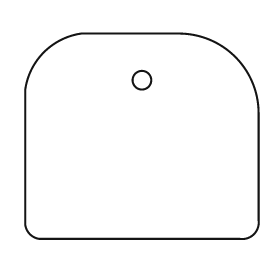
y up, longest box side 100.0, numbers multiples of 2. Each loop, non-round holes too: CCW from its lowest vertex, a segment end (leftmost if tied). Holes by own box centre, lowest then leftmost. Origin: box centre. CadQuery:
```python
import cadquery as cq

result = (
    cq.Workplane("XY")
    .moveTo(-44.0, -44.0)
    .lineTo(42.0, -44.0)
    .threePointArc((48.0, -42.0), (50.0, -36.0))
    .lineTo(50.0, 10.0)
    .threePointArc((40.0, 34.0), (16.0, 44.0))
    .lineTo(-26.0, 44.0)
    .threePointArc((-42.0, 36.0), (-50.0, 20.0))
    .lineTo(-50.0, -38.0)
    .threePointArc((-48.0, -42.0), (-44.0, -44.0))
    .close()
    .moveTo(0.0, 24.0)
    .circle(4.0)
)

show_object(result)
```